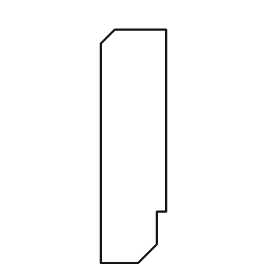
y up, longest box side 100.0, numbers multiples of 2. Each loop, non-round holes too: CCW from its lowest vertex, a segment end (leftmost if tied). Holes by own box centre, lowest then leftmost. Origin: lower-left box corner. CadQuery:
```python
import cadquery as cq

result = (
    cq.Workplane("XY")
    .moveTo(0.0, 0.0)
    .lineTo(16.0, 0.0)
    .lineTo(24.0, 8.0)
    .lineTo(24.0, 22.0)
    .lineTo(28.0, 22.0)
    .lineTo(28.0, 100.0)
    .lineTo(6.0, 100.0)
    .lineTo(0.0, 94.0)
    .close()
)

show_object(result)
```